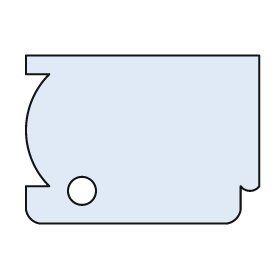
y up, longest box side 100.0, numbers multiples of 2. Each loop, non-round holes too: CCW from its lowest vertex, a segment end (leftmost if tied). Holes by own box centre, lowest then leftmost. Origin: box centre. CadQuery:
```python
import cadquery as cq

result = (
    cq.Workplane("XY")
    .moveTo(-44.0, -36.0)
    .lineTo(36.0, -36.0)
    .threePointArc((40.0, -34.0), (42.0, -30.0))
    .lineTo(42.0, -20.0)
    .threePointArc((46.0, -22.0), (50.0, -20.0))
    .lineTo(50.0, 36.0)
    .lineTo(-50.0, 36.0)
    .lineTo(-50.0, 28.0)
    .lineTo(-40.0, 28.0)
    .threePointArc((-50.0, 4.0), (-40.0, -20.0))
    .lineTo(-50.0, -20.0)
    .lineTo(-50.0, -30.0)
    .threePointArc((-48.0, -34.0), (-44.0, -36.0))
    .close()
    .moveTo(-26.0, -22.0)
    .circle(6.0)
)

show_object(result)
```